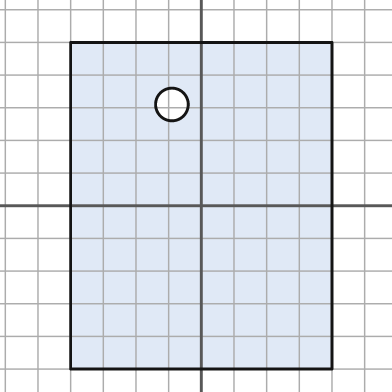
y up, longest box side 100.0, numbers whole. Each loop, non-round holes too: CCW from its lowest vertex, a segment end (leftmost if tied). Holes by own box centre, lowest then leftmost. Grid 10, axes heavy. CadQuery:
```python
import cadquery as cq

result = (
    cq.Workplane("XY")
    .moveTo(-40.0, -50.0)
    .lineTo(40.0, -50.0)
    .lineTo(40.0, 50.0)
    .lineTo(-40.0, 50.0)
    .close()
    .moveTo(-9.0, 31.0)
    .circle(5.0)
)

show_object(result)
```